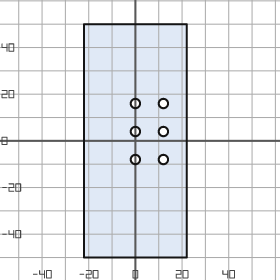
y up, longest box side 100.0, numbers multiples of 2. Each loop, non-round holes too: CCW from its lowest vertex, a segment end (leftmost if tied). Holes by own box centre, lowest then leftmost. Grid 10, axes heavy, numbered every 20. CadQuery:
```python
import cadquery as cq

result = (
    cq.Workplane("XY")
    .moveTo(-22.0, -50.0)
    .lineTo(22.0, -50.0)
    .lineTo(22.0, 50.0)
    .lineTo(-22.0, 50.0)
    .close()
    .moveTo(0.0, -8.0)
    .circle(2.0)
    .moveTo(12.0, -8.0)
    .circle(2.0)
    .moveTo(0.0, 4.0)
    .circle(2.0)
    .moveTo(12.0, 4.0)
    .circle(2.0)
    .moveTo(0.0, 16.0)
    .circle(2.0)
    .moveTo(12.0, 16.0)
    .circle(2.0)
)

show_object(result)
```